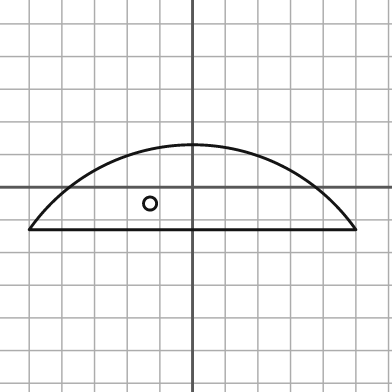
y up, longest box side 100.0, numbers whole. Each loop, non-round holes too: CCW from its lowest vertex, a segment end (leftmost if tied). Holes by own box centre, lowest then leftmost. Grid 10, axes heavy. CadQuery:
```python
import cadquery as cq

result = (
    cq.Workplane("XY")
    .moveTo(-50.0, -13.0)
    .lineTo(50.0, -13.0)
    .threePointArc((0.0, 13.0), (-50.0, -13.0))
    .close()
    .moveTo(-13.0, -5.0)
    .circle(2.0)
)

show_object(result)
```